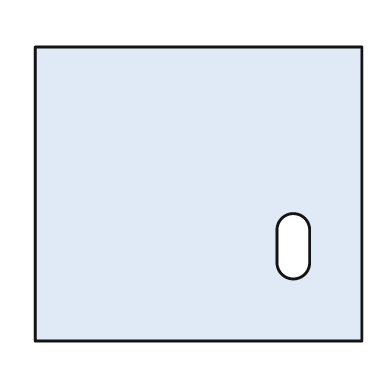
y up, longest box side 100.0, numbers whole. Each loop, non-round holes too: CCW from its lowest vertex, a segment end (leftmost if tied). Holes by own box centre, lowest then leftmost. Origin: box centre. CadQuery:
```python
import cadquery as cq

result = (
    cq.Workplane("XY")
    .moveTo(-50.0, -45.0)
    .lineTo(50.0, -45.0)
    .lineTo(50.0, 45.0)
    .lineTo(-50.0, 45.0)
    .close()
    .moveTo(24.0, -21.0)
    .threePointArc((29.0, -26.0), (34.0, -21.0))
    .lineTo(34.0, -11.0)
    .threePointArc((29.0, -6.0), (24.0, -11.0))
    .close()
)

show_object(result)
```